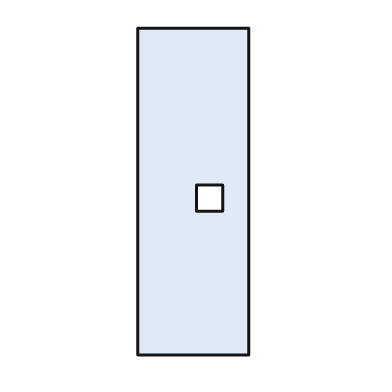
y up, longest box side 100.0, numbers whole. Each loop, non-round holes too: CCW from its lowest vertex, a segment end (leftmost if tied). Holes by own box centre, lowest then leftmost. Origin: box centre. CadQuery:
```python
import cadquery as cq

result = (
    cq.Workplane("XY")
    .moveTo(-17.0, -50.0)
    .lineTo(17.0, -50.0)
    .lineTo(17.0, 50.0)
    .lineTo(-17.0, 50.0)
    .close()
    .moveTo(1.0, -6.0)
    .lineTo(9.0, -6.0)
    .lineTo(9.0, 2.0)
    .lineTo(1.0, 2.0)
    .close()
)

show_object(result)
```